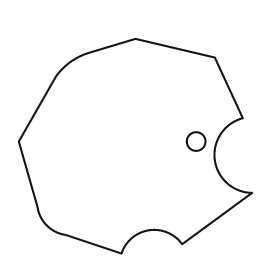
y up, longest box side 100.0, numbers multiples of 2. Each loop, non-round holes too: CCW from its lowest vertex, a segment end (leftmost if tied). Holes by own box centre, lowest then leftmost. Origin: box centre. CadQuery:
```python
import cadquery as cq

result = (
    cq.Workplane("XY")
    .moveTo(-6.0, -46.0)
    .threePointArc((6.0, -36.0), (20.0, -42.0))
    .lineTo(50.0, -20.0)
    .threePointArc((34.0, -6.0), (46.0, 12.0))
    .lineTo(34.0, 38.0)
    .lineTo(0.0, 46.0)
    .lineTo(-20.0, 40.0)
    .threePointArc((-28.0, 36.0), (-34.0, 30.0))
    .lineTo(-50.0, 2.0)
    .lineTo(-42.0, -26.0)
    .threePointArc((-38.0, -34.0), (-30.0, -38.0))
    .close()
    .moveTo(26.0, 2.0)
    .circle(4.0)
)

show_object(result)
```